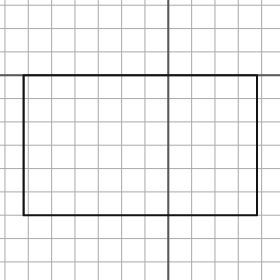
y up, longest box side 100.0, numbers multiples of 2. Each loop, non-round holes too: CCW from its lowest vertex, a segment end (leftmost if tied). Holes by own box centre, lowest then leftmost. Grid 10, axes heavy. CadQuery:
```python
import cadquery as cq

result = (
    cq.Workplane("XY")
    .moveTo(-62.0, -60.0)
    .lineTo(38.0, -60.0)
    .lineTo(38.0, 0.0)
    .lineTo(-62.0, 0.0)
    .close()
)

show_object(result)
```